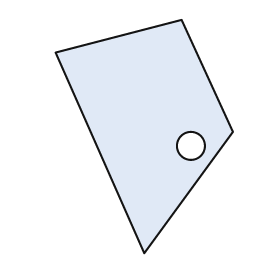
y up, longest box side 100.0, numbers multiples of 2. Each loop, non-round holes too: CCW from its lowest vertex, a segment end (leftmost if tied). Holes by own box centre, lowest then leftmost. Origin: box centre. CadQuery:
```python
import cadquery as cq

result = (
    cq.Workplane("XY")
    .moveTo(0.0, -50.0)
    .lineTo(38.0, 2.0)
    .lineTo(16.0, 50.0)
    .lineTo(-38.0, 36.0)
    .close()
    .moveTo(20.0, -4.0)
    .circle(6.0)
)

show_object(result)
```